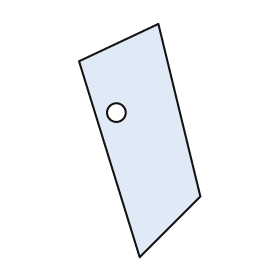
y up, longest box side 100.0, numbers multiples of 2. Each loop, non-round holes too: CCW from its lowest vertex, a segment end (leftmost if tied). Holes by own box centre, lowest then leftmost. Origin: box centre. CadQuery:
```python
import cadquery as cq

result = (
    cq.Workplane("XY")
    .moveTo(0.0, -50.0)
    .lineTo(26.0, -24.0)
    .lineTo(8.0, 50.0)
    .lineTo(-26.0, 34.0)
    .close()
    .moveTo(-10.0, 12.0)
    .circle(4.0)
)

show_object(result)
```